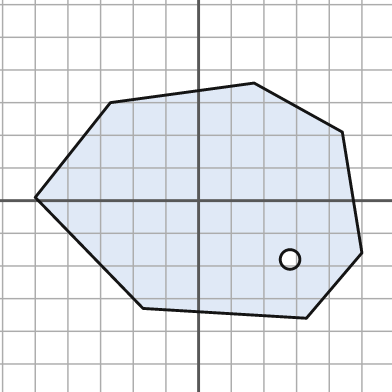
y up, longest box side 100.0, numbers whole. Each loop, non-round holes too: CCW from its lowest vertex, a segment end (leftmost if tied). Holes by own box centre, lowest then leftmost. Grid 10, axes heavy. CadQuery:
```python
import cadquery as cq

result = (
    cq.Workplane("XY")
    .moveTo(33.0, -36.0)
    .lineTo(50.0, -16.0)
    .lineTo(44.0, 21.0)
    .lineTo(17.0, 36.0)
    .lineTo(-27.0, 30.0)
    .lineTo(-50.0, 1.0)
    .lineTo(-17.0, -33.0)
    .close()
    .moveTo(28.0, -18.0)
    .circle(3.0)
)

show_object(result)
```